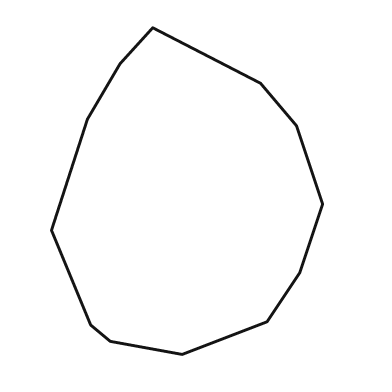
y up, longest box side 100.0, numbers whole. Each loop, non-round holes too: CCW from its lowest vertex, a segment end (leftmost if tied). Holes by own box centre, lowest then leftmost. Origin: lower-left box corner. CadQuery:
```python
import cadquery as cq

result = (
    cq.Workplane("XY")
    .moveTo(40.0, 0.0)
    .lineTo(66.0, 10.0)
    .lineTo(76.0, 25.0)
    .lineTo(83.0, 46.0)
    .lineTo(75.0, 70.0)
    .lineTo(64.0, 83.0)
    .lineTo(31.0, 100.0)
    .lineTo(21.0, 89.0)
    .lineTo(11.0, 72.0)
    .lineTo(0.0, 38.0)
    .lineTo(12.0, 9.0)
    .lineTo(18.0, 4.0)
    .close()
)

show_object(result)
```